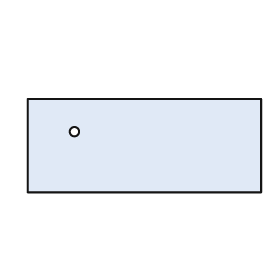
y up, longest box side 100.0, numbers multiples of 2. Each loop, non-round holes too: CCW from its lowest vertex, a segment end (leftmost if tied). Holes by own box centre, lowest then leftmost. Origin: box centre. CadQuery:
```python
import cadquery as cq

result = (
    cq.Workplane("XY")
    .moveTo(-50.0, -20.0)
    .lineTo(50.0, -20.0)
    .lineTo(50.0, 20.0)
    .lineTo(-50.0, 20.0)
    .close()
    .moveTo(-30.0, 6.0)
    .circle(2.0)
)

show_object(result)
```